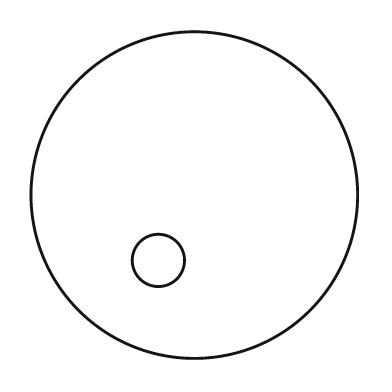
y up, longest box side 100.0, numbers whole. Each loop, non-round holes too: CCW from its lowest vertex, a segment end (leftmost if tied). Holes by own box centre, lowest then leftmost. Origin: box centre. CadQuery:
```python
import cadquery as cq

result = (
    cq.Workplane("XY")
    .moveTo(0.0, 0.0)
    .circle(50.0)
    .moveTo(-11.0, -20.0)
    .circle(8.0)
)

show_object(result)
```